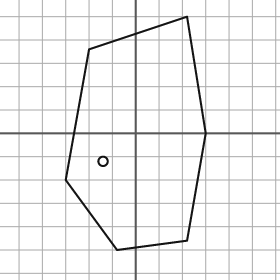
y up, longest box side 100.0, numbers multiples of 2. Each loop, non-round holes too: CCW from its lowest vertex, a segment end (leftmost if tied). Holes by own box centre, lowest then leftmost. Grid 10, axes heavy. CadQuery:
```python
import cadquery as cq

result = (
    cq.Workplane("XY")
    .moveTo(-8.0, -50.0)
    .lineTo(22.0, -46.0)
    .lineTo(30.0, 0.0)
    .lineTo(22.0, 50.0)
    .lineTo(-20.0, 36.0)
    .lineTo(-30.0, -20.0)
    .close()
    .moveTo(-14.0, -12.0)
    .circle(2.0)
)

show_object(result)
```